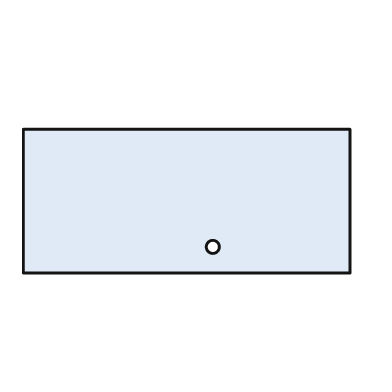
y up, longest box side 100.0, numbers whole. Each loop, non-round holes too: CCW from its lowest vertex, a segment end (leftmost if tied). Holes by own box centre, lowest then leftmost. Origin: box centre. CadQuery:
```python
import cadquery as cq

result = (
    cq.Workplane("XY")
    .moveTo(-50.0, -22.0)
    .lineTo(50.0, -22.0)
    .lineTo(50.0, 22.0)
    .lineTo(-50.0, 22.0)
    .close()
    .moveTo(8.0, -14.0)
    .circle(2.0)
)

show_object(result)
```